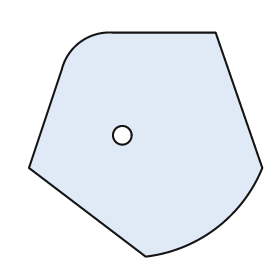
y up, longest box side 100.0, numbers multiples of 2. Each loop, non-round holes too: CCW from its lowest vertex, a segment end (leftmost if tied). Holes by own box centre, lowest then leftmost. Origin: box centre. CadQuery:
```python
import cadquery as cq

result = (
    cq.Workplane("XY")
    .moveTo(0.0, -48.0)
    .threePointArc((30.0, -36.0), (50.0, -10.0))
    .lineTo(30.0, 48.0)
    .lineTo(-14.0, 48.0)
    .threePointArc((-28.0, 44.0), (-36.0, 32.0))
    .lineTo(-50.0, -10.0)
    .close()
    .moveTo(-10.0, 4.0)
    .circle(4.0)
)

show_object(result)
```